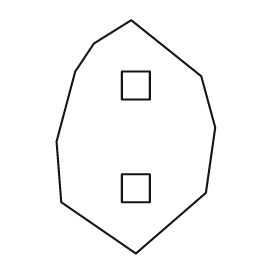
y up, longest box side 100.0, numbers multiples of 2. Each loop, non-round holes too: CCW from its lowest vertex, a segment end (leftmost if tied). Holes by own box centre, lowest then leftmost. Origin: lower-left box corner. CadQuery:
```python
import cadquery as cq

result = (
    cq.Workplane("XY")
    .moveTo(34.0, 0.0)
    .lineTo(64.0, 26.0)
    .lineTo(68.0, 54.0)
    .lineTo(62.0, 76.0)
    .lineTo(32.0, 100.0)
    .lineTo(16.0, 90.0)
    .lineTo(8.0, 78.0)
    .lineTo(0.0, 48.0)
    .lineTo(2.0, 22.0)
    .close()
    .moveTo(28.0, 22.0)
    .lineTo(40.0, 22.0)
    .lineTo(40.0, 34.0)
    .lineTo(28.0, 34.0)
    .close()
    .moveTo(28.0, 66.0)
    .lineTo(40.0, 66.0)
    .lineTo(40.0, 78.0)
    .lineTo(28.0, 78.0)
    .close()
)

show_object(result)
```